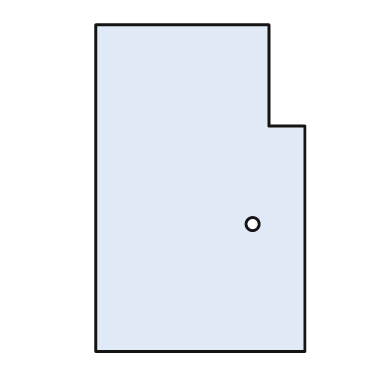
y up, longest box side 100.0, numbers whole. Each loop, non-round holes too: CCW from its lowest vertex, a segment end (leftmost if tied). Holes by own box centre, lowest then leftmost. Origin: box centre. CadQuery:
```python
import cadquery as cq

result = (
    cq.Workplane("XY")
    .moveTo(-32.0, -50.0)
    .lineTo(32.0, -50.0)
    .lineTo(32.0, 19.0)
    .lineTo(21.0, 19.0)
    .lineTo(21.0, 50.0)
    .lineTo(-32.0, 50.0)
    .close()
    .moveTo(16.0, -11.0)
    .circle(2.0)
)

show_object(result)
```